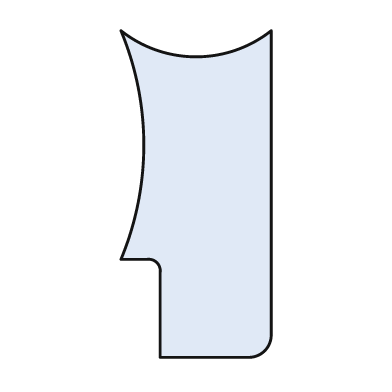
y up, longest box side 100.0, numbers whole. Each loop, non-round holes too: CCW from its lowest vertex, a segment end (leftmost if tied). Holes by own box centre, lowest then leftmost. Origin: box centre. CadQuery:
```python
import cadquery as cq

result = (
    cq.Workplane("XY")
    .moveTo(-11.0, -50.0)
    .lineTo(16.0, -50.0)
    .threePointArc((21.0, -48.0), (23.0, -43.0))
    .lineTo(23.0, 50.0)
    .threePointArc((0.0, 42.0), (-23.0, 50.0))
    .threePointArc((-16.0, 15.0), (-23.0, -20.0))
    .lineTo(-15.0, -20.0)
    .threePointArc((-12.0, -21.0), (-11.0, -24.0))
    .close()
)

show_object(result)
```